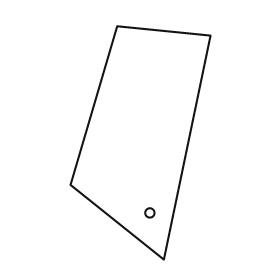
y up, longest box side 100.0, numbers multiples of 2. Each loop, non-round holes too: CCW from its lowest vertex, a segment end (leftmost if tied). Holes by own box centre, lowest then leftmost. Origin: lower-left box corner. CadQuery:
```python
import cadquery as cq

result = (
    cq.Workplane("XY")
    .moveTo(40.0, 0.0)
    .lineTo(60.0, 96.0)
    .lineTo(20.0, 100.0)
    .lineTo(0.0, 32.0)
    .close()
    .moveTo(34.0, 20.0)
    .circle(2.0)
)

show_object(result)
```